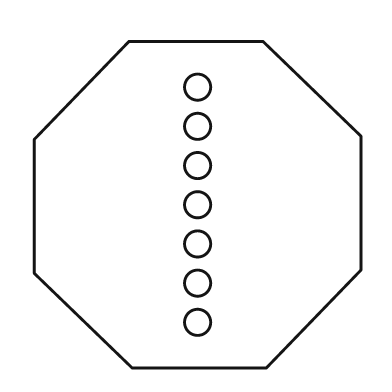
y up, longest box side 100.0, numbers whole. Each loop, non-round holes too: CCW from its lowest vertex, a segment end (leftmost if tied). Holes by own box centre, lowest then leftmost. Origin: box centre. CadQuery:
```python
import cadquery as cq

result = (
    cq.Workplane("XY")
    .moveTo(-20.0, -50.0)
    .lineTo(21.0, -50.0)
    .lineTo(50.0, -20.0)
    .lineTo(50.0, 21.0)
    .lineTo(20.0, 50.0)
    .lineTo(-21.0, 50.0)
    .lineTo(-50.0, 20.0)
    .lineTo(-50.0, -21.0)
    .close()
    .moveTo(0.0, -36.0)
    .circle(4.0)
    .moveTo(0.0, -24.0)
    .circle(4.0)
    .moveTo(0.0, -12.0)
    .circle(4.0)
    .moveTo(0.0, 0.0)
    .circle(4.0)
    .moveTo(0.0, 12.0)
    .circle(4.0)
    .moveTo(0.0, 24.0)
    .circle(4.0)
    .moveTo(0.0, 36.0)
    .circle(4.0)
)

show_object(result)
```